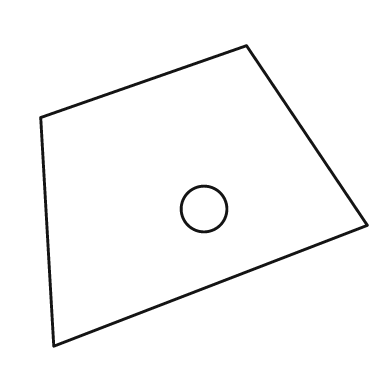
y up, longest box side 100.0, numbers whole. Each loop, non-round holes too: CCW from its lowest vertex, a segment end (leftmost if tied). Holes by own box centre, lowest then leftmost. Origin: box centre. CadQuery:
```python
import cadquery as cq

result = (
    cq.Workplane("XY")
    .moveTo(-46.0, -46.0)
    .lineTo(50.0, -9.0)
    .lineTo(13.0, 46.0)
    .lineTo(-50.0, 24.0)
    .close()
    .moveTo(0.0, -4.0)
    .circle(7.0)
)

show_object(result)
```